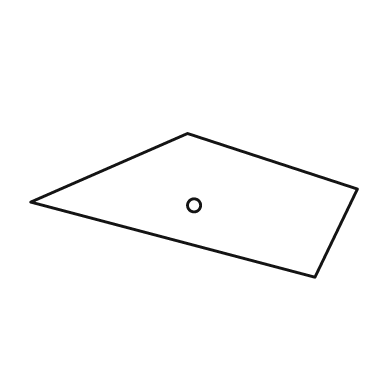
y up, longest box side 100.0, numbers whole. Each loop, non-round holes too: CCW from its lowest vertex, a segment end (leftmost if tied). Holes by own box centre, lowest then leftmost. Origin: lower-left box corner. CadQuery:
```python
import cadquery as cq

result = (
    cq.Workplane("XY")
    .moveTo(87.0, 0.0)
    .lineTo(100.0, 27.0)
    .lineTo(48.0, 44.0)
    .lineTo(0.0, 23.0)
    .close()
    .moveTo(50.0, 22.0)
    .circle(2.0)
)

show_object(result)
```